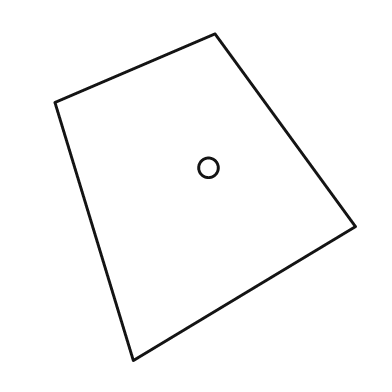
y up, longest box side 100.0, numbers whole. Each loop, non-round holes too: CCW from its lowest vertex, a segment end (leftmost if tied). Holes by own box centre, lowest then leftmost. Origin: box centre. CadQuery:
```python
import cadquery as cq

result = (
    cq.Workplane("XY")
    .moveTo(-22.0, -50.0)
    .lineTo(46.0, -9.0)
    .lineTo(3.0, 50.0)
    .lineTo(-46.0, 29.0)
    .close()
    .moveTo(1.0, 9.0)
    .circle(3.0)
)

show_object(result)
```